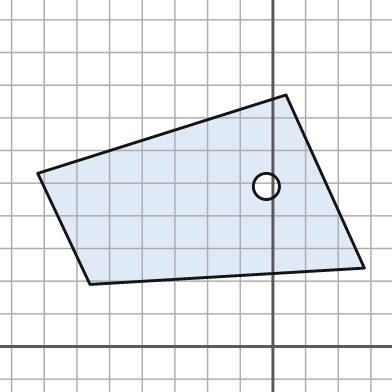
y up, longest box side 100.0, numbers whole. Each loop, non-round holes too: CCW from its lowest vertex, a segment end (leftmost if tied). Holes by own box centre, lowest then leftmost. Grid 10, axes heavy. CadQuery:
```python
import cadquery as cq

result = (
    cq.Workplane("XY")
    .moveTo(-56.0, 19.0)
    .lineTo(28.0, 24.0)
    .lineTo(4.0, 77.0)
    .lineTo(-72.0, 53.0)
    .close()
    .moveTo(-2.0, 49.0)
    .circle(4.0)
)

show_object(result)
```